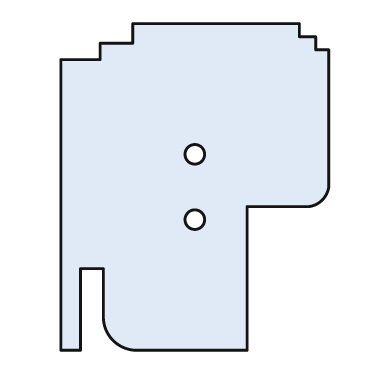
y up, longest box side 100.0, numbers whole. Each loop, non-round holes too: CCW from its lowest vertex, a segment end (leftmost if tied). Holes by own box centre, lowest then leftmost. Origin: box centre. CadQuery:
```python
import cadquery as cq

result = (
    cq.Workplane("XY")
    .moveTo(-41.0, -50.0)
    .lineTo(-35.0, -50.0)
    .lineTo(-35.0, -25.0)
    .lineTo(-28.0, -25.0)
    .lineTo(-28.0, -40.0)
    .threePointArc((-25.0, -47.0), (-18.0, -50.0))
    .lineTo(16.0, -50.0)
    .lineTo(16.0, -6.0)
    .lineTo(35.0, -6.0)
    .threePointArc((39.0, -4.0), (41.0, 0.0))
    .lineTo(41.0, 42.0)
    .lineTo(37.0, 42.0)
    .lineTo(37.0, 46.0)
    .lineTo(32.0, 46.0)
    .lineTo(32.0, 50.0)
    .lineTo(-19.0, 50.0)
    .lineTo(-19.0, 44.0)
    .lineTo(-29.0, 44.0)
    .lineTo(-29.0, 39.0)
    .lineTo(-41.0, 39.0)
    .close()
    .moveTo(0.0, -10.0)
    .circle(3.0)
    .moveTo(0.0, 10.0)
    .circle(3.0)
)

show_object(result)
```